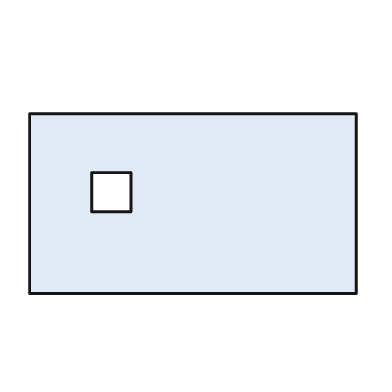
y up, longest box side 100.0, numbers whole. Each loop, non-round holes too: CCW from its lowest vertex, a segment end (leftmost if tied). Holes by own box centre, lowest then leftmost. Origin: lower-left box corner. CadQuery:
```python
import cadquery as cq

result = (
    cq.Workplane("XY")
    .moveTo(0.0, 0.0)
    .lineTo(100.0, 0.0)
    .lineTo(100.0, 55.0)
    .lineTo(0.0, 55.0)
    .close()
    .moveTo(19.0, 25.0)
    .lineTo(31.0, 25.0)
    .lineTo(31.0, 37.0)
    .lineTo(19.0, 37.0)
    .close()
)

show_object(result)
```